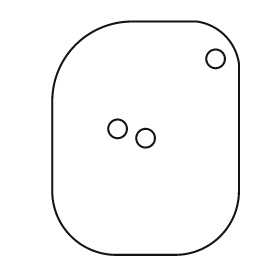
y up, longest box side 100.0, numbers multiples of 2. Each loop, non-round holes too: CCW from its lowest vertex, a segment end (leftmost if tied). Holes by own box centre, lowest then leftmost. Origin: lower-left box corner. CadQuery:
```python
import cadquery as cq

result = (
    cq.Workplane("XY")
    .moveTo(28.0, 0.0)
    .lineTo(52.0, 0.0)
    .threePointArc((72.0, 8.0), (80.0, 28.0))
    .lineTo(80.0, 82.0)
    .threePointArc((74.0, 94.0), (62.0, 100.0))
    .lineTo(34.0, 100.0)
    .threePointArc((10.0, 90.0), (0.0, 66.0))
    .lineTo(0.0, 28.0)
    .threePointArc((8.0, 8.0), (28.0, 0.0))
    .close()
    .moveTo(40.0, 50.0)
    .circle(4.0)
    .moveTo(28.0, 54.0)
    .circle(4.0)
    .moveTo(70.0, 84.0)
    .circle(4.0)
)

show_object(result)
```